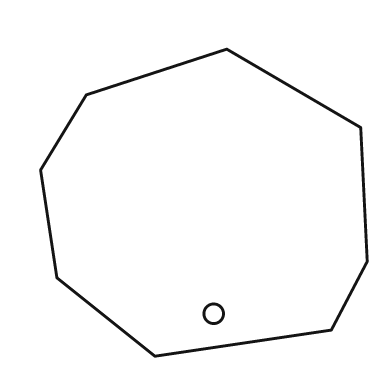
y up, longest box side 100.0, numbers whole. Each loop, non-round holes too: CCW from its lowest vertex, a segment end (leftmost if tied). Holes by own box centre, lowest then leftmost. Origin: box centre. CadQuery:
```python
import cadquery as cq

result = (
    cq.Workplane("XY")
    .moveTo(-15.0, -47.0)
    .lineTo(39.0, -39.0)
    .lineTo(50.0, -18.0)
    .lineTo(48.0, 23.0)
    .lineTo(7.0, 47.0)
    .lineTo(-36.0, 33.0)
    .lineTo(-50.0, 10.0)
    .lineTo(-45.0, -23.0)
    .close()
    .moveTo(3.0, -34.0)
    .circle(3.0)
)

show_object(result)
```